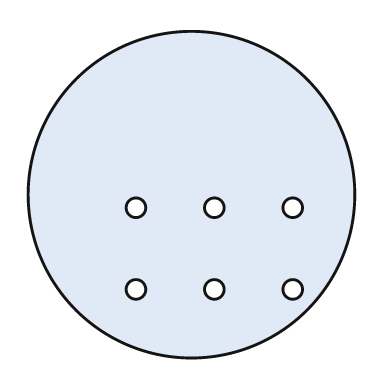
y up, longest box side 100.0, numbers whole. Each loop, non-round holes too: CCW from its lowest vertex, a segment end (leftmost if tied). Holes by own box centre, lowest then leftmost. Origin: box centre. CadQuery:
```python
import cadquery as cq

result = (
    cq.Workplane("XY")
    .moveTo(0.0, 0.0)
    .circle(50.0)
    .moveTo(-17.0, -29.0)
    .circle(3.0)
    .moveTo(7.0, -29.0)
    .circle(3.0)
    .moveTo(31.0, -29.0)
    .circle(3.0)
    .moveTo(-17.0, -4.0)
    .circle(3.0)
    .moveTo(7.0, -4.0)
    .circle(3.0)
    .moveTo(31.0, -4.0)
    .circle(3.0)
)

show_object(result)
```